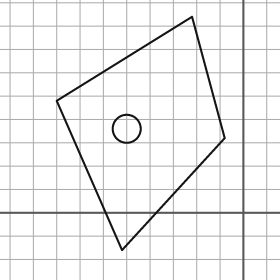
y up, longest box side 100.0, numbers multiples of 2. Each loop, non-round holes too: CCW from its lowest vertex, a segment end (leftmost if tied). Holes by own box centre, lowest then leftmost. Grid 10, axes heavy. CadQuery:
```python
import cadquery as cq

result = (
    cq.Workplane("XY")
    .moveTo(-52.0, -16.0)
    .lineTo(-8.0, 32.0)
    .lineTo(-22.0, 84.0)
    .lineTo(-80.0, 48.0)
    .close()
    .moveTo(-50.0, 36.0)
    .circle(6.0)
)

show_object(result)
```